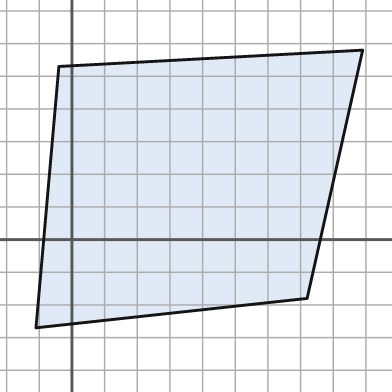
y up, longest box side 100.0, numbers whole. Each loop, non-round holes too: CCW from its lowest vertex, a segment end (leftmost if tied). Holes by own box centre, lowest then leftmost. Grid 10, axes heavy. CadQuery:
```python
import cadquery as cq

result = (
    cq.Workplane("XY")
    .moveTo(-11.0, -27.0)
    .lineTo(72.0, -18.0)
    .lineTo(89.0, 58.0)
    .lineTo(-4.0, 53.0)
    .close()
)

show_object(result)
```